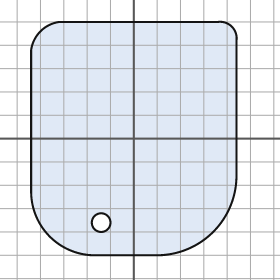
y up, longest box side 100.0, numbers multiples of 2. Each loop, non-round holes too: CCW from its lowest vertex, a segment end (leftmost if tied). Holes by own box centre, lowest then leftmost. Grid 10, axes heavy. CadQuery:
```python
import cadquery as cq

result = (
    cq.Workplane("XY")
    .moveTo(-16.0, -50.0)
    .lineTo(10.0, -50.0)
    .threePointArc((34.0, -40.0), (44.0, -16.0))
    .lineTo(44.0, 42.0)
    .threePointArc((42.0, 48.0), (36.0, 50.0))
    .lineTo(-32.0, 50.0)
    .threePointArc((-40.0, 46.0), (-44.0, 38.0))
    .lineTo(-44.0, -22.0)
    .threePointArc((-36.0, -42.0), (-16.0, -50.0))
    .close()
    .moveTo(-14.0, -36.0)
    .circle(4.0)
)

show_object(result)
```